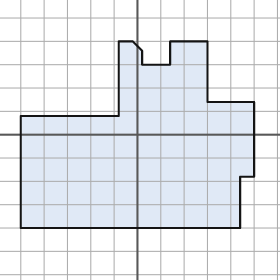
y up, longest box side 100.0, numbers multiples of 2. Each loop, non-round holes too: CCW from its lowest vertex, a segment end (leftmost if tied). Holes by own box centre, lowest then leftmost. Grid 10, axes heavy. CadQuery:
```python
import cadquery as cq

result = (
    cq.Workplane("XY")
    .moveTo(-50.0, -40.0)
    .lineTo(44.0, -40.0)
    .lineTo(44.0, -18.0)
    .lineTo(50.0, -18.0)
    .lineTo(50.0, 14.0)
    .lineTo(30.0, 14.0)
    .lineTo(30.0, 40.0)
    .lineTo(14.0, 40.0)
    .lineTo(14.0, 30.0)
    .lineTo(2.0, 30.0)
    .lineTo(2.0, 36.0)
    .lineTo(-2.0, 40.0)
    .lineTo(-8.0, 40.0)
    .lineTo(-8.0, 8.0)
    .lineTo(-50.0, 8.0)
    .close()
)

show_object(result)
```